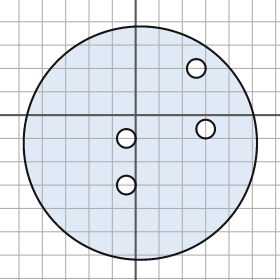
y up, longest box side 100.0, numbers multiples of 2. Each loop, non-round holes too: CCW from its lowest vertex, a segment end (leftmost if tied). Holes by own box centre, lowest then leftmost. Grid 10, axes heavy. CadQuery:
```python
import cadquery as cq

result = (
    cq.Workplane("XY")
    .moveTo(2.0, -12.0)
    .circle(50.0)
    .moveTo(-4.0, -30.0)
    .circle(4.0)
    .moveTo(-4.0, -10.0)
    .circle(4.0)
    .moveTo(30.0, -6.0)
    .circle(4.0)
    .moveTo(26.0, 20.0)
    .circle(4.0)
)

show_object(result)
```